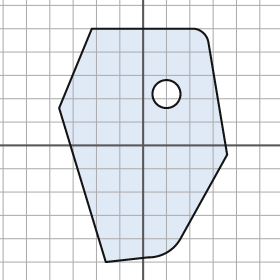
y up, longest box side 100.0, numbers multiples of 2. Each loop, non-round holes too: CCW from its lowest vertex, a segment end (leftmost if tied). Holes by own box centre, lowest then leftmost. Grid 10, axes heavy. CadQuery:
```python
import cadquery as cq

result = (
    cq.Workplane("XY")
    .moveTo(-16.0, -50.0)
    .lineTo(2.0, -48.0)
    .threePointArc((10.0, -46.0), (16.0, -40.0))
    .lineTo(36.0, -4.0)
    .lineTo(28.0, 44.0)
    .threePointArc((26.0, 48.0), (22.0, 50.0))
    .lineTo(-22.0, 50.0)
    .lineTo(-36.0, 16.0)
    .close()
    .moveTo(10.0, 22.0)
    .circle(6.0)
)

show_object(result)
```